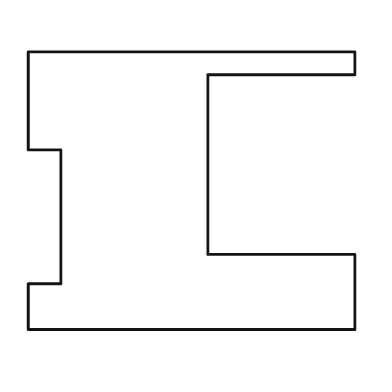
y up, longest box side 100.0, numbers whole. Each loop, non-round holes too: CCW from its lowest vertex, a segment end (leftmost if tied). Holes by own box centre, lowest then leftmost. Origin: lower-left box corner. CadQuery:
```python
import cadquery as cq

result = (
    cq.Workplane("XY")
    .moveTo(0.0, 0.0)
    .lineTo(100.0, 0.0)
    .lineTo(100.0, 23.0)
    .lineTo(55.0, 23.0)
    .lineTo(55.0, 78.0)
    .lineTo(100.0, 78.0)
    .lineTo(100.0, 85.0)
    .lineTo(0.0, 85.0)
    .lineTo(0.0, 55.0)
    .lineTo(10.0, 55.0)
    .lineTo(10.0, 14.0)
    .lineTo(0.0, 14.0)
    .close()
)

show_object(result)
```